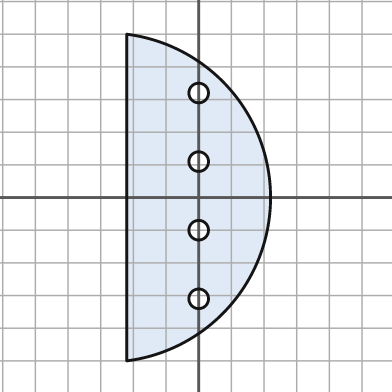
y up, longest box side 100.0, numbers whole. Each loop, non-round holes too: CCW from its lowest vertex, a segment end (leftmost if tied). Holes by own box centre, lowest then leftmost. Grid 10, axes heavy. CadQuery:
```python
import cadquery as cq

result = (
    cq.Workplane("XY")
    .moveTo(-22.0, -50.0)
    .threePointArc((22.0, 0.0), (-22.0, 50.0))
    .close()
    .moveTo(0.0, -31.0)
    .circle(3.0)
    .moveTo(0.0, -10.0)
    .circle(3.0)
    .moveTo(0.0, 11.0)
    .circle(3.0)
    .moveTo(0.0, 32.0)
    .circle(3.0)
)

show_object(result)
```